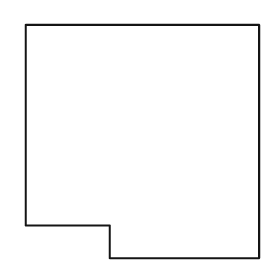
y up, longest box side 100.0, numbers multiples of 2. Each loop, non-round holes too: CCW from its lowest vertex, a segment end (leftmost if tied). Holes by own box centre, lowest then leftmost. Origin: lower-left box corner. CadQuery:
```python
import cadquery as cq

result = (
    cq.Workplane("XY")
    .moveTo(36.0, 0.0)
    .lineTo(100.0, 0.0)
    .lineTo(100.0, 100.0)
    .lineTo(0.0, 100.0)
    .lineTo(0.0, 14.0)
    .lineTo(36.0, 14.0)
    .close()
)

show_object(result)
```